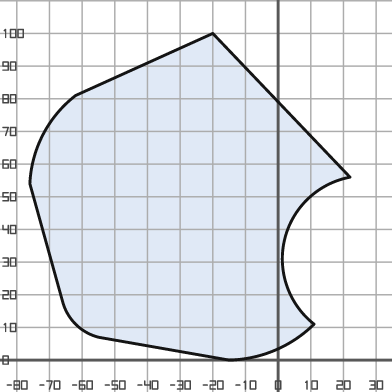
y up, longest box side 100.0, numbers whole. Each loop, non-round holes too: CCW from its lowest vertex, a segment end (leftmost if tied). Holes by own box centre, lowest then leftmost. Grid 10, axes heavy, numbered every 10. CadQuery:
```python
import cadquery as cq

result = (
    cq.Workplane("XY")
    .moveTo(-15.0, 0.0)
    .threePointArc((-1.0, 3.0), (11.0, 11.0))
    .threePointArc((2.0, 37.0), (22.0, 56.0))
    .lineTo(-20.0, 100.0)
    .lineTo(-62.0, 81.0)
    .threePointArc((-72.0, 69.0), (-76.0, 54.0))
    .lineTo(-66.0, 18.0)
    .threePointArc((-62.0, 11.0), (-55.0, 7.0))
    .close()
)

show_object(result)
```